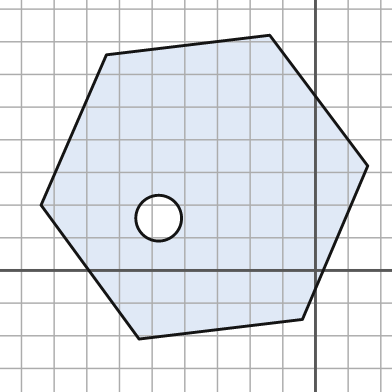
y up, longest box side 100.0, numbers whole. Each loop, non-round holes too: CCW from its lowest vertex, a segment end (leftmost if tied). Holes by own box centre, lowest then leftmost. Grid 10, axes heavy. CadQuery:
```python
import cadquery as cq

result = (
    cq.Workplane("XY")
    .moveTo(-54.0, -21.0)
    .lineTo(-4.0, -15.0)
    .lineTo(16.0, 32.0)
    .lineTo(-14.0, 72.0)
    .lineTo(-64.0, 66.0)
    .lineTo(-84.0, 20.0)
    .close()
    .moveTo(-48.0, 16.0)
    .circle(7.0)
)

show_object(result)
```